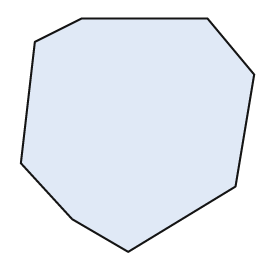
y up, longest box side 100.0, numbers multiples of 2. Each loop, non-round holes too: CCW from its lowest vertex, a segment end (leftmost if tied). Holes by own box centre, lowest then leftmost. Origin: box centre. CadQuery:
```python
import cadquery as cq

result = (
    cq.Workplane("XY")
    .moveTo(-4.0, -50.0)
    .lineTo(42.0, -22.0)
    .lineTo(50.0, 26.0)
    .lineTo(30.0, 50.0)
    .lineTo(-24.0, 50.0)
    .lineTo(-44.0, 40.0)
    .lineTo(-50.0, -12.0)
    .lineTo(-28.0, -36.0)
    .close()
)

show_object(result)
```